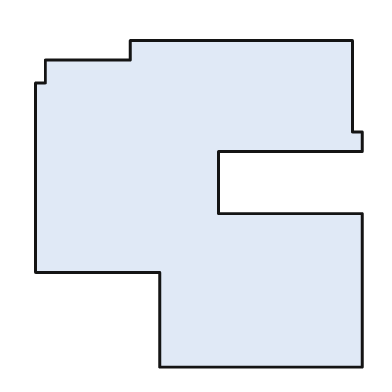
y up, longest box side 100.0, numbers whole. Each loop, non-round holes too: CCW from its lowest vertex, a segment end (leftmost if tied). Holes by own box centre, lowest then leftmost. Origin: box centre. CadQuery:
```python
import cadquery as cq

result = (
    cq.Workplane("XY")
    .moveTo(-12.0, -50.0)
    .lineTo(50.0, -50.0)
    .lineTo(50.0, -3.0)
    .lineTo(6.0, -3.0)
    .lineTo(6.0, 16.0)
    .lineTo(50.0, 16.0)
    .lineTo(50.0, 22.0)
    .lineTo(47.0, 22.0)
    .lineTo(47.0, 50.0)
    .lineTo(-21.0, 50.0)
    .lineTo(-21.0, 44.0)
    .lineTo(-47.0, 44.0)
    .lineTo(-47.0, 37.0)
    .lineTo(-50.0, 37.0)
    .lineTo(-50.0, -21.0)
    .lineTo(-12.0, -21.0)
    .close()
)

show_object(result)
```